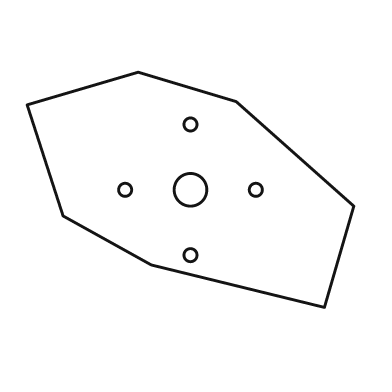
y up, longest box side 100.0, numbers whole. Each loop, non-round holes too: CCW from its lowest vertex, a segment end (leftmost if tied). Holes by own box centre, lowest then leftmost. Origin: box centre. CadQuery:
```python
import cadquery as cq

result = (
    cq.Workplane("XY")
    .moveTo(41.0, -36.0)
    .lineTo(50.0, -5.0)
    .lineTo(14.0, 27.0)
    .lineTo(-16.0, 36.0)
    .lineTo(-50.0, 26.0)
    .lineTo(-39.0, -8.0)
    .lineTo(-12.0, -23.0)
    .close()
    .moveTo(0.0, -20.0)
    .circle(2.0)
    .moveTo(-20.0, 0.0)
    .circle(2.0)
    .moveTo(0.0, 0.0)
    .circle(5.0)
    .moveTo(20.0, 0.0)
    .circle(2.0)
    .moveTo(0.0, 20.0)
    .circle(2.0)
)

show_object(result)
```